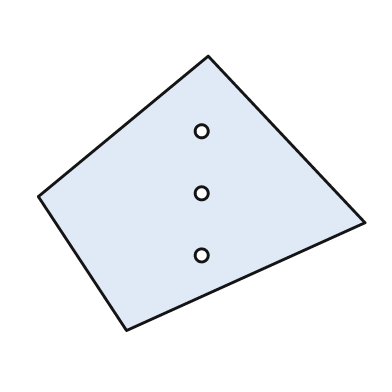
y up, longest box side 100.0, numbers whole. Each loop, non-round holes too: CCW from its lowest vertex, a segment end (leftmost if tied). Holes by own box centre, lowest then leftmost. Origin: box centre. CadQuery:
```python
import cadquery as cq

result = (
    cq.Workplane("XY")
    .moveTo(-23.0, -42.0)
    .lineTo(50.0, -9.0)
    .lineTo(2.0, 42.0)
    .lineTo(-50.0, -1.0)
    .close()
    .moveTo(0.0, -19.0)
    .circle(2.0)
    .moveTo(0.0, 0.0)
    .circle(2.0)
    .moveTo(0.0, 19.0)
    .circle(2.0)
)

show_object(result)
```